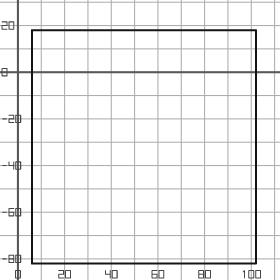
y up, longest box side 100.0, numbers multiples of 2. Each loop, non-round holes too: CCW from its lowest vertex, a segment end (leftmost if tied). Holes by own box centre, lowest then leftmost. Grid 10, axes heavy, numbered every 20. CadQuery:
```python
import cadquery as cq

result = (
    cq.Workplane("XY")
    .moveTo(6.0, -82.0)
    .lineTo(102.0, -82.0)
    .lineTo(102.0, 18.0)
    .lineTo(6.0, 18.0)
    .close()
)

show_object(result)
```